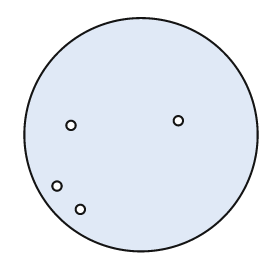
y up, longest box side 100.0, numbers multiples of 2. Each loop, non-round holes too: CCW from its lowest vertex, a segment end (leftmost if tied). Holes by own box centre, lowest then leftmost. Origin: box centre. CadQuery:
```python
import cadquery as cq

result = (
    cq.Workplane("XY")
    .moveTo(0.0, 0.0)
    .circle(50.0)
    .moveTo(-26.0, -32.0)
    .circle(2.0)
    .moveTo(-36.0, -22.0)
    .circle(2.0)
    .moveTo(-30.0, 4.0)
    .circle(2.0)
    .moveTo(16.0, 6.0)
    .circle(2.0)
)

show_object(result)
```